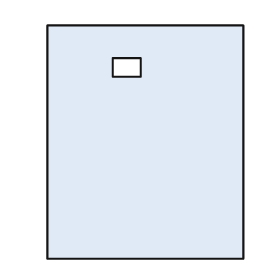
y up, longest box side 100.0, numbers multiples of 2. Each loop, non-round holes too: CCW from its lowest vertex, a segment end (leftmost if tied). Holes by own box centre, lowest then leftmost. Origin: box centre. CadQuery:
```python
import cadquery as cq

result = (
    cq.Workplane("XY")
    .moveTo(-42.0, -50.0)
    .lineTo(42.0, -50.0)
    .lineTo(42.0, 50.0)
    .lineTo(-42.0, 50.0)
    .close()
    .moveTo(-14.0, 28.0)
    .lineTo(-2.0, 28.0)
    .lineTo(-2.0, 36.0)
    .lineTo(-14.0, 36.0)
    .close()
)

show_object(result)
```